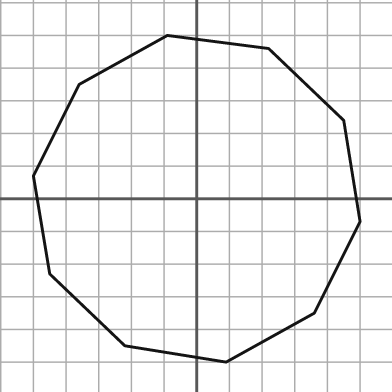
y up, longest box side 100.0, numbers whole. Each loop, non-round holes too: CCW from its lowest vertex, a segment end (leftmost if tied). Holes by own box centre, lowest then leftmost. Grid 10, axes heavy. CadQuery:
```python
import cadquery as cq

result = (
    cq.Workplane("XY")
    .moveTo(9.0, -50.0)
    .lineTo(36.0, -35.0)
    .lineTo(50.0, -7.0)
    .lineTo(45.0, 24.0)
    .lineTo(22.0, 46.0)
    .lineTo(-9.0, 50.0)
    .lineTo(-36.0, 35.0)
    .lineTo(-50.0, 7.0)
    .lineTo(-45.0, -23.0)
    .lineTo(-22.0, -45.0)
    .close()
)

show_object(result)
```